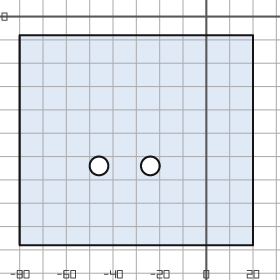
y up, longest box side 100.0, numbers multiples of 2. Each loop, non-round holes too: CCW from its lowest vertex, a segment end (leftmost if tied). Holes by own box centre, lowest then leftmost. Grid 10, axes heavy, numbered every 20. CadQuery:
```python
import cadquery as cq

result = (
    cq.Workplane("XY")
    .moveTo(-80.0, -98.0)
    .lineTo(20.0, -98.0)
    .lineTo(20.0, -8.0)
    .lineTo(-80.0, -8.0)
    .close()
    .moveTo(-46.0, -64.0)
    .circle(4.0)
    .moveTo(-24.0, -64.0)
    .circle(4.0)
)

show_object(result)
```